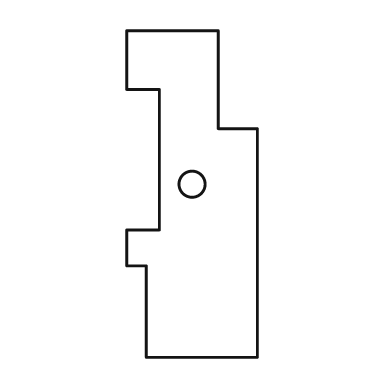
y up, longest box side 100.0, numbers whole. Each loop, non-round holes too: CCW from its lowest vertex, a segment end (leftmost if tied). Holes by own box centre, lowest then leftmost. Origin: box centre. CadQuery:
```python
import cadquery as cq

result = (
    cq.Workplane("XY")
    .moveTo(-14.0, -50.0)
    .lineTo(20.0, -50.0)
    .lineTo(20.0, 20.0)
    .lineTo(8.0, 20.0)
    .lineTo(8.0, 50.0)
    .lineTo(-20.0, 50.0)
    .lineTo(-20.0, 32.0)
    .lineTo(-10.0, 32.0)
    .lineTo(-10.0, -11.0)
    .lineTo(-20.0, -11.0)
    .lineTo(-20.0, -22.0)
    .lineTo(-14.0, -22.0)
    .close()
    .moveTo(0.0, 3.0)
    .circle(4.0)
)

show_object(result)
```